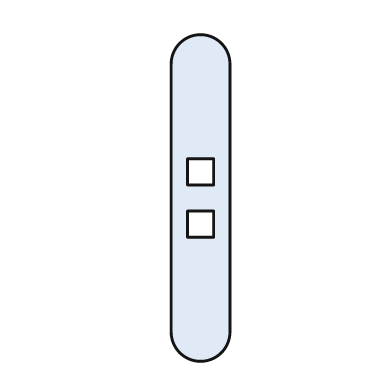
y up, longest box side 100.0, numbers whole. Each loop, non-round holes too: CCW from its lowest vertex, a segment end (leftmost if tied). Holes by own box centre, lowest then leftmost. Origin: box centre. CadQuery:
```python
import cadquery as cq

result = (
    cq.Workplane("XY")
    .moveTo(-9.0, -41.0)
    .threePointArc((0.0, -50.0), (9.0, -41.0))
    .lineTo(9.0, 41.0)
    .threePointArc((0.0, 50.0), (-9.0, 41.0))
    .close()
    .moveTo(-4.0, -12.0)
    .lineTo(4.0, -12.0)
    .lineTo(4.0, -4.0)
    .lineTo(-4.0, -4.0)
    .close()
    .moveTo(-4.0, 4.0)
    .lineTo(4.0, 4.0)
    .lineTo(4.0, 12.0)
    .lineTo(-4.0, 12.0)
    .close()
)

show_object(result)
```